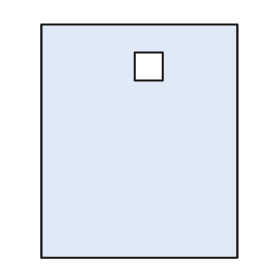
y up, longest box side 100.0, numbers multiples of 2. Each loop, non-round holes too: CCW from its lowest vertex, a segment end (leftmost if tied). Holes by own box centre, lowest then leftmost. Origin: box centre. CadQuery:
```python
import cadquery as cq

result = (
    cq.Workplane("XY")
    .moveTo(-42.0, -50.0)
    .lineTo(42.0, -50.0)
    .lineTo(42.0, 50.0)
    .lineTo(-42.0, 50.0)
    .close()
    .moveTo(-2.0, 26.0)
    .lineTo(10.0, 26.0)
    .lineTo(10.0, 38.0)
    .lineTo(-2.0, 38.0)
    .close()
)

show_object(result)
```